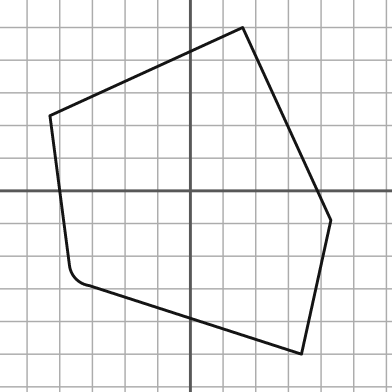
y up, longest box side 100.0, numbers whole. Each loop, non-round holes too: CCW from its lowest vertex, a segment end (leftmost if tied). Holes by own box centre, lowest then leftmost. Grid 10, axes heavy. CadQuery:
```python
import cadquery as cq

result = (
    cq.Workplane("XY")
    .moveTo(34.0, -50.0)
    .lineTo(43.0, -9.0)
    .lineTo(16.0, 50.0)
    .lineTo(-43.0, 23.0)
    .lineTo(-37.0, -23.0)
    .threePointArc((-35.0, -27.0), (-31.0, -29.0))
    .close()
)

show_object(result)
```